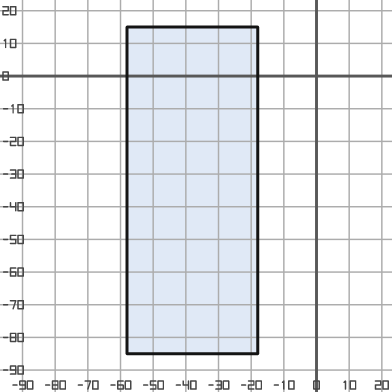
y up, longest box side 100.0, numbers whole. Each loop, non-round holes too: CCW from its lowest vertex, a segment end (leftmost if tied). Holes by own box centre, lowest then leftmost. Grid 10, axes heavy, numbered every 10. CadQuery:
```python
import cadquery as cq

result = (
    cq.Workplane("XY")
    .moveTo(-58.0, -85.0)
    .lineTo(-18.0, -85.0)
    .lineTo(-18.0, 15.0)
    .lineTo(-58.0, 15.0)
    .close()
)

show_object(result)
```